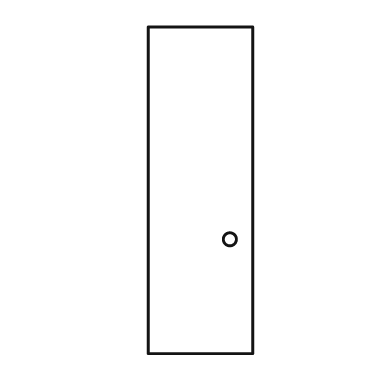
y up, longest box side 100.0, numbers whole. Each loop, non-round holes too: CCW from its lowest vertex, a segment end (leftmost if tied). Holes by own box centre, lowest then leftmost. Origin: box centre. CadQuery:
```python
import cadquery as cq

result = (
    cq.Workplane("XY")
    .moveTo(-16.0, -50.0)
    .lineTo(16.0, -50.0)
    .lineTo(16.0, 50.0)
    .lineTo(-16.0, 50.0)
    .close()
    .moveTo(9.0, -15.0)
    .circle(2.0)
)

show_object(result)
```